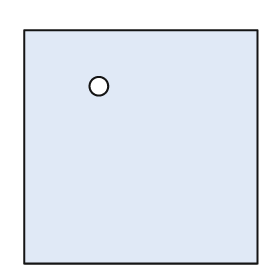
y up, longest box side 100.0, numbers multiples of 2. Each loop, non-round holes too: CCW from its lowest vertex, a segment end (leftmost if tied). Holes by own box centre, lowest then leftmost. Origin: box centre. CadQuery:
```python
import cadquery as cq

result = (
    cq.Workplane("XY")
    .moveTo(-50.0, -50.0)
    .lineTo(50.0, -50.0)
    .lineTo(50.0, 50.0)
    .lineTo(-50.0, 50.0)
    .close()
    .moveTo(-18.0, 26.0)
    .circle(4.0)
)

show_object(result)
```